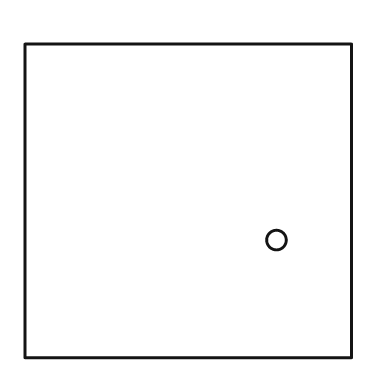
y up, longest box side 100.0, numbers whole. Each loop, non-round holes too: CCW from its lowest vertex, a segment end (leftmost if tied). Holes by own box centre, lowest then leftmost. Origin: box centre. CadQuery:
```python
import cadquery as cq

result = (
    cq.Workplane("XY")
    .moveTo(-50.0, -48.0)
    .lineTo(50.0, -48.0)
    .lineTo(50.0, 48.0)
    .lineTo(-50.0, 48.0)
    .close()
    .moveTo(27.0, -12.0)
    .circle(3.0)
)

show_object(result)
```